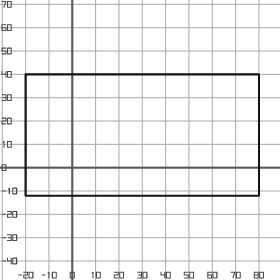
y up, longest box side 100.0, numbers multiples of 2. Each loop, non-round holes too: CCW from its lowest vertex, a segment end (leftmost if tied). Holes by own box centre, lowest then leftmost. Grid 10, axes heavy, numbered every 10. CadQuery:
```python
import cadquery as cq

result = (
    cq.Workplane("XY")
    .moveTo(-20.0, -12.0)
    .lineTo(80.0, -12.0)
    .lineTo(80.0, 40.0)
    .lineTo(-20.0, 40.0)
    .close()
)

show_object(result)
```